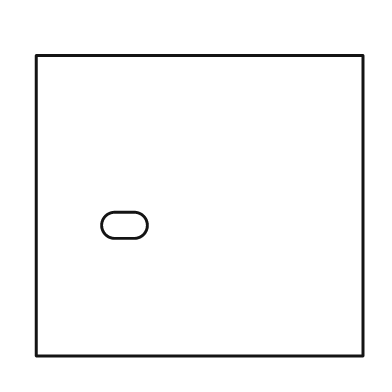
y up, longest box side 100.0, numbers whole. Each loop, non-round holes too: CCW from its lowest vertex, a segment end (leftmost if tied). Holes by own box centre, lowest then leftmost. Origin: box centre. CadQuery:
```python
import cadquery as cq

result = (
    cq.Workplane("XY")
    .moveTo(-50.0, -46.0)
    .lineTo(50.0, -46.0)
    .lineTo(50.0, 46.0)
    .lineTo(-50.0, 46.0)
    .close()
    .moveTo(-26.0, -10.0)
    .lineTo(-20.0, -10.0)
    .threePointArc((-16.0, -6.0), (-20.0, -2.0))
    .lineTo(-26.0, -2.0)
    .threePointArc((-30.0, -6.0), (-26.0, -10.0))
    .close()
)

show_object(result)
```